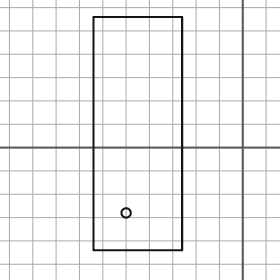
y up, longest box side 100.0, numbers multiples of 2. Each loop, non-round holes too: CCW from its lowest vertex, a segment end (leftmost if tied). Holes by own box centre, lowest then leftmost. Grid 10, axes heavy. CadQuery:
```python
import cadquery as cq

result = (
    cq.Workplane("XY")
    .moveTo(-64.0, -44.0)
    .lineTo(-26.0, -44.0)
    .lineTo(-26.0, 56.0)
    .lineTo(-64.0, 56.0)
    .close()
    .moveTo(-50.0, -28.0)
    .circle(2.0)
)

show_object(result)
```